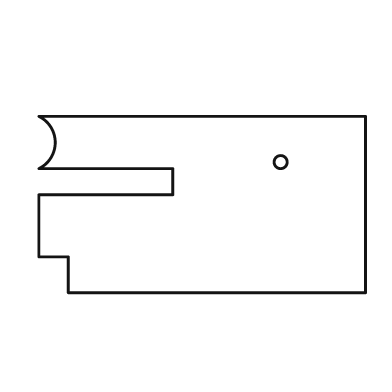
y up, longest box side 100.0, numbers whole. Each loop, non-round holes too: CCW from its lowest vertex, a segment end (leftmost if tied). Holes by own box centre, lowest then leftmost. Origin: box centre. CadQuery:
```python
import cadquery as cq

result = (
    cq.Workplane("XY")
    .moveTo(-41.0, -27.0)
    .lineTo(50.0, -27.0)
    .lineTo(50.0, 27.0)
    .lineTo(-50.0, 27.0)
    .threePointArc((-45.0, 19.0), (-50.0, 11.0))
    .lineTo(-9.0, 11.0)
    .lineTo(-9.0, 3.0)
    .lineTo(-50.0, 3.0)
    .lineTo(-50.0, -16.0)
    .lineTo(-41.0, -16.0)
    .close()
    .moveTo(24.0, 13.0)
    .circle(2.0)
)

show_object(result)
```